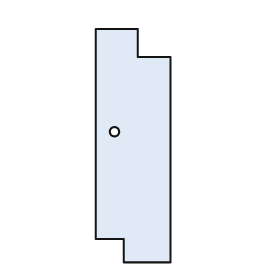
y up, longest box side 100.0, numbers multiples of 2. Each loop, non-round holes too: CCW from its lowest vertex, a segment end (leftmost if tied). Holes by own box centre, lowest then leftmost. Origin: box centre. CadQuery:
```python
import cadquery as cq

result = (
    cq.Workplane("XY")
    .moveTo(-4.0, -50.0)
    .lineTo(16.0, -50.0)
    .lineTo(16.0, 38.0)
    .lineTo(2.0, 38.0)
    .lineTo(2.0, 50.0)
    .lineTo(-16.0, 50.0)
    .lineTo(-16.0, -40.0)
    .lineTo(-4.0, -40.0)
    .close()
    .moveTo(-8.0, 6.0)
    .circle(2.0)
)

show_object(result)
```